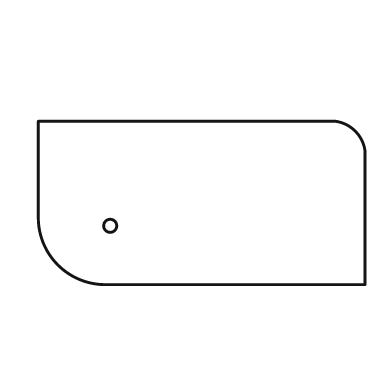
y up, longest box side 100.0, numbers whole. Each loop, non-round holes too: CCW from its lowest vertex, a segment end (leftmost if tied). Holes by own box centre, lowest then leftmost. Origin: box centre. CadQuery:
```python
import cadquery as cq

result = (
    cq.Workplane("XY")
    .moveTo(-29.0, -25.0)
    .lineTo(50.0, -25.0)
    .lineTo(50.0, 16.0)
    .threePointArc((47.0, 22.0), (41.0, 25.0))
    .lineTo(-50.0, 25.0)
    .lineTo(-50.0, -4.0)
    .threePointArc((-44.0, -19.0), (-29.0, -25.0))
    .close()
    .moveTo(-28.0, -7.0)
    .circle(2.0)
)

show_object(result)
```